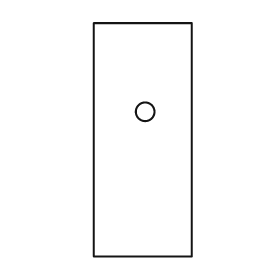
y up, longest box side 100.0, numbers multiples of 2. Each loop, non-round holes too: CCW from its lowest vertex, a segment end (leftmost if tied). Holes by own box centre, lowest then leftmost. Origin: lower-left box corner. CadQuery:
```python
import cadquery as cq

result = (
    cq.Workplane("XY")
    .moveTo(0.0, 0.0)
    .lineTo(42.0, 0.0)
    .lineTo(42.0, 100.0)
    .lineTo(0.0, 100.0)
    .close()
    .moveTo(22.0, 62.0)
    .circle(4.0)
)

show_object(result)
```